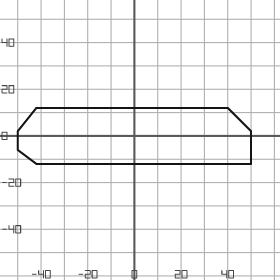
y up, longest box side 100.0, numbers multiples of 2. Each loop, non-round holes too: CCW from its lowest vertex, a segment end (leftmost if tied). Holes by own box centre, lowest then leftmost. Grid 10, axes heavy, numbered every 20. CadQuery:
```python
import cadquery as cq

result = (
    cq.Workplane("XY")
    .moveTo(-42.0, -12.0)
    .lineTo(50.0, -12.0)
    .lineTo(50.0, 2.0)
    .lineTo(40.0, 12.0)
    .lineTo(-42.0, 12.0)
    .lineTo(-50.0, 2.0)
    .lineTo(-50.0, -6.0)
    .close()
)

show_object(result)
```